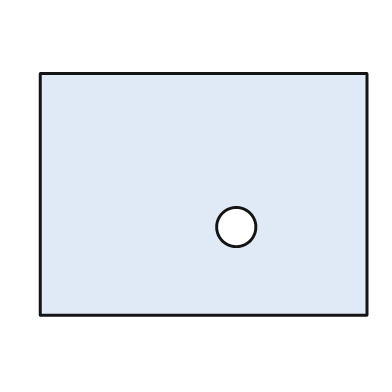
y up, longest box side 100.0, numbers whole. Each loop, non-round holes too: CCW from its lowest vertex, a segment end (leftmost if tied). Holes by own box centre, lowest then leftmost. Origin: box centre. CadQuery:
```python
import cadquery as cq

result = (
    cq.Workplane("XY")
    .moveTo(-50.0, -37.0)
    .lineTo(50.0, -37.0)
    .lineTo(50.0, 37.0)
    .lineTo(-50.0, 37.0)
    .close()
    .moveTo(10.0, -10.0)
    .circle(6.0)
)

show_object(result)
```